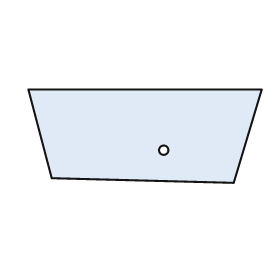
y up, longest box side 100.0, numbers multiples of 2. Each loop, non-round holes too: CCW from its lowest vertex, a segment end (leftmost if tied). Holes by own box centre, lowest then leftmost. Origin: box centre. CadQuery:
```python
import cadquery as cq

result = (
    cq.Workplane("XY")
    .moveTo(38.0, -20.0)
    .lineTo(50.0, 20.0)
    .lineTo(-50.0, 20.0)
    .lineTo(-40.0, -18.0)
    .close()
    .moveTo(8.0, -6.0)
    .circle(2.0)
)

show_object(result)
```